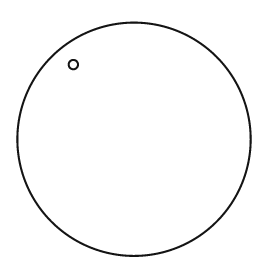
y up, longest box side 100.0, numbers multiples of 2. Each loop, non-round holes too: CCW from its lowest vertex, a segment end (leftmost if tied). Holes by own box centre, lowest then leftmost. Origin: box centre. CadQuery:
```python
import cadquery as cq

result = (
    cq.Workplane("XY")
    .moveTo(0.0, 0.0)
    .circle(50.0)
    .moveTo(-26.0, 32.0)
    .circle(2.0)
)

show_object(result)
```